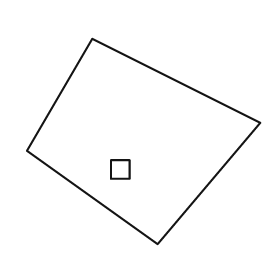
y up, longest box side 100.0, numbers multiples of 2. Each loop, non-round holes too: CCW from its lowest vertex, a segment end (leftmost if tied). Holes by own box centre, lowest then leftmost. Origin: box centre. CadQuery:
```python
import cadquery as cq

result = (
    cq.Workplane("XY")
    .moveTo(6.0, -44.0)
    .lineTo(50.0, 8.0)
    .lineTo(-22.0, 44.0)
    .lineTo(-50.0, -4.0)
    .close()
    .moveTo(-14.0, -16.0)
    .lineTo(-6.0, -16.0)
    .lineTo(-6.0, -8.0)
    .lineTo(-14.0, -8.0)
    .close()
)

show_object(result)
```